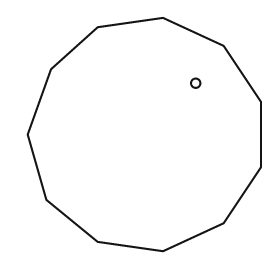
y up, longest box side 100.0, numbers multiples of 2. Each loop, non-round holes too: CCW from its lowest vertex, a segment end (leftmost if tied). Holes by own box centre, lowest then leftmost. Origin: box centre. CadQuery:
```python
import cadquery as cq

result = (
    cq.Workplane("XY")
    .moveTo(8.0, -50.0)
    .lineTo(34.0, -38.0)
    .lineTo(50.0, -14.0)
    .lineTo(50.0, 14.0)
    .lineTo(34.0, 38.0)
    .lineTo(8.0, 50.0)
    .lineTo(-20.0, 46.0)
    .lineTo(-40.0, 28.0)
    .lineTo(-50.0, 0.0)
    .lineTo(-42.0, -28.0)
    .lineTo(-20.0, -46.0)
    .close()
    .moveTo(22.0, 22.0)
    .circle(2.0)
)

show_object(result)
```